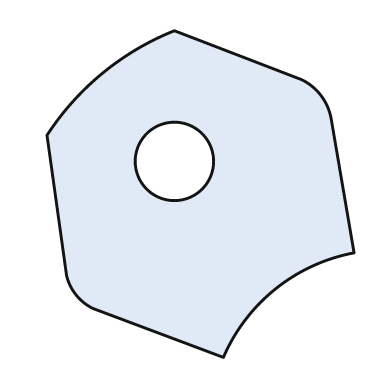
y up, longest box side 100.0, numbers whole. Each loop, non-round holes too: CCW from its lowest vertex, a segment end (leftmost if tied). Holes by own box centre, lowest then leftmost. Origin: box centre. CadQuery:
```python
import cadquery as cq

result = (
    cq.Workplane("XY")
    .moveTo(7.0, -50.0)
    .threePointArc((23.0, -29.0), (47.0, -18.0))
    .lineTo(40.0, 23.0)
    .threePointArc((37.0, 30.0), (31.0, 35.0))
    .lineTo(-8.0, 50.0)
    .threePointArc((-30.0, 37.0), (-47.0, 18.0))
    .lineTo(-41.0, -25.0)
    .threePointArc((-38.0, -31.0), (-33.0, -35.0))
    .close()
    .moveTo(-8.0, 10.0)
    .circle(12.0)
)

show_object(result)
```